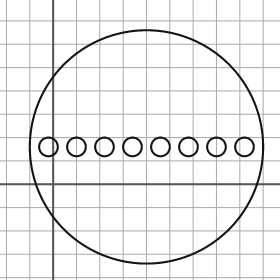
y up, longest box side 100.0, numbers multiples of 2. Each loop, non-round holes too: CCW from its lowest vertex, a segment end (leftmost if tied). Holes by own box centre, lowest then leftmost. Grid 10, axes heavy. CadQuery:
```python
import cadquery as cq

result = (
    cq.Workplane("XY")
    .moveTo(40.0, 16.0)
    .circle(50.0)
    .moveTo(-2.0, 16.0)
    .circle(4.0)
    .moveTo(10.0, 16.0)
    .circle(4.0)
    .moveTo(22.0, 16.0)
    .circle(4.0)
    .moveTo(34.0, 16.0)
    .circle(4.0)
    .moveTo(46.0, 16.0)
    .circle(4.0)
    .moveTo(58.0, 16.0)
    .circle(4.0)
    .moveTo(70.0, 16.0)
    .circle(4.0)
    .moveTo(82.0, 16.0)
    .circle(4.0)
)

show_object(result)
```